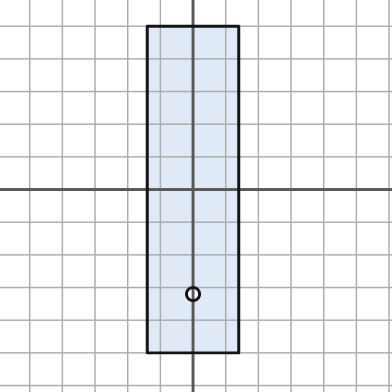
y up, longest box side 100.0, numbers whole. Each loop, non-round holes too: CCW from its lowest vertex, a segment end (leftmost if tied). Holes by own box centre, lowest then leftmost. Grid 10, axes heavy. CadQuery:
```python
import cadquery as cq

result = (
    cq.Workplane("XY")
    .moveTo(-14.0, -50.0)
    .lineTo(14.0, -50.0)
    .lineTo(14.0, 50.0)
    .lineTo(-14.0, 50.0)
    .close()
    .moveTo(0.0, -32.0)
    .circle(2.0)
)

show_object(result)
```